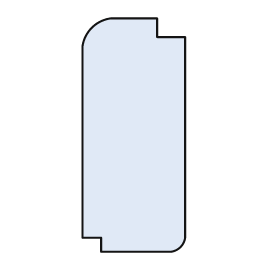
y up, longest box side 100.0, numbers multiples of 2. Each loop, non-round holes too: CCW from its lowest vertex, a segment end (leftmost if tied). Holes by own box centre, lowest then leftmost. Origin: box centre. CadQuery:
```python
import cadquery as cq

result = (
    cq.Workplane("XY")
    .moveTo(-14.0, -50.0)
    .lineTo(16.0, -50.0)
    .threePointArc((20.0, -48.0), (22.0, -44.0))
    .lineTo(22.0, 42.0)
    .lineTo(10.0, 42.0)
    .lineTo(10.0, 50.0)
    .lineTo(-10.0, 50.0)
    .threePointArc((-18.0, 46.0), (-22.0, 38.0))
    .lineTo(-22.0, -44.0)
    .lineTo(-14.0, -44.0)
    .close()
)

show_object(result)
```